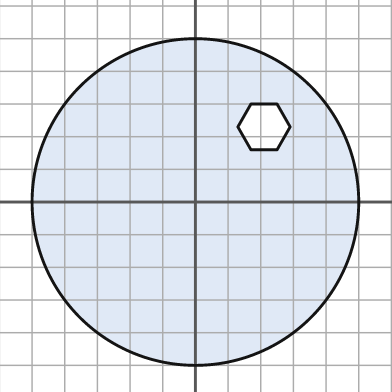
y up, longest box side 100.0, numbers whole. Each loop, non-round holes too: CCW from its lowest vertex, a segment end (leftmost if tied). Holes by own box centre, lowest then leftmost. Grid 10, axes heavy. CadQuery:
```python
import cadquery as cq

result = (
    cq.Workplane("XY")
    .moveTo(0.0, 0.0)
    .circle(50.0)
    .moveTo(17.0, 16.0)
    .lineTo(25.0, 16.0)
    .lineTo(29.0, 23.0)
    .lineTo(25.0, 30.0)
    .lineTo(17.0, 30.0)
    .lineTo(13.0, 23.0)
    .close()
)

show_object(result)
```